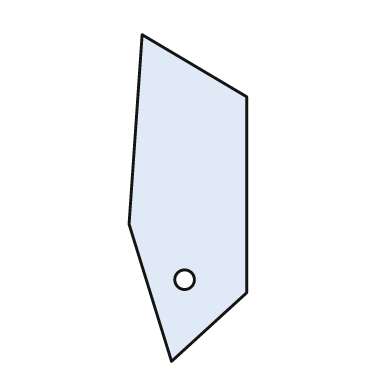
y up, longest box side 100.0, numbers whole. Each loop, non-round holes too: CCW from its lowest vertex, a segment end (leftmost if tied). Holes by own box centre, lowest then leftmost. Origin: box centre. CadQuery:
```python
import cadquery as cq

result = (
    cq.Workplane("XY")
    .moveTo(-5.0, -50.0)
    .lineTo(18.0, -29.0)
    .lineTo(18.0, 31.0)
    .lineTo(-14.0, 50.0)
    .lineTo(-18.0, -8.0)
    .close()
    .moveTo(-1.0, -25.0)
    .circle(3.0)
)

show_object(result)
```